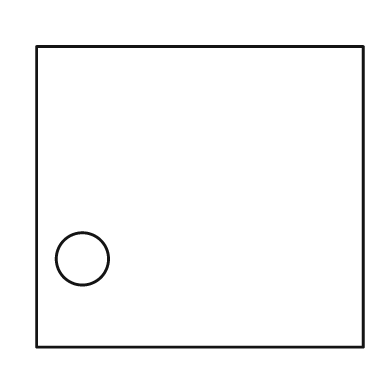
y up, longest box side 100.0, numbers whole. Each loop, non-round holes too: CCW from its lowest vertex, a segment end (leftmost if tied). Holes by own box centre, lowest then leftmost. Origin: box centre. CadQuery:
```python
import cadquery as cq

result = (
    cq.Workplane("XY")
    .moveTo(-50.0, -46.0)
    .lineTo(50.0, -46.0)
    .lineTo(50.0, 46.0)
    .lineTo(-50.0, 46.0)
    .close()
    .moveTo(-36.0, -19.0)
    .circle(8.0)
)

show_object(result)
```